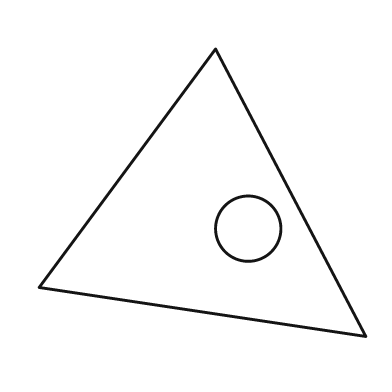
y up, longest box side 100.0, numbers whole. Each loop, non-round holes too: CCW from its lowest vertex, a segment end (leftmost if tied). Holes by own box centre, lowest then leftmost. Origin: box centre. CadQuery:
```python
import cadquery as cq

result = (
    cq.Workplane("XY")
    .moveTo(50.0, -44.0)
    .lineTo(4.0, 44.0)
    .lineTo(-50.0, -29.0)
    .close()
    .moveTo(14.0, -11.0)
    .circle(10.0)
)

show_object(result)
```